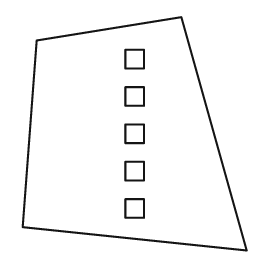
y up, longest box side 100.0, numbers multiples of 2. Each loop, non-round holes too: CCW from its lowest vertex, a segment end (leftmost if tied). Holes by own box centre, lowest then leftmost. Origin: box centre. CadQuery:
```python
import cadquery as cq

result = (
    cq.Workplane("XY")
    .moveTo(48.0, -50.0)
    .lineTo(20.0, 50.0)
    .lineTo(-42.0, 40.0)
    .lineTo(-48.0, -40.0)
    .close()
    .moveTo(-4.0, -36.0)
    .lineTo(4.0, -36.0)
    .lineTo(4.0, -28.0)
    .lineTo(-4.0, -28.0)
    .close()
    .moveTo(-4.0, -20.0)
    .lineTo(4.0, -20.0)
    .lineTo(4.0, -12.0)
    .lineTo(-4.0, -12.0)
    .close()
    .moveTo(-4.0, -4.0)
    .lineTo(4.0, -4.0)
    .lineTo(4.0, 4.0)
    .lineTo(-4.0, 4.0)
    .close()
    .moveTo(-4.0, 12.0)
    .lineTo(4.0, 12.0)
    .lineTo(4.0, 20.0)
    .lineTo(-4.0, 20.0)
    .close()
    .moveTo(-4.0, 28.0)
    .lineTo(4.0, 28.0)
    .lineTo(4.0, 36.0)
    .lineTo(-4.0, 36.0)
    .close()
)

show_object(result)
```